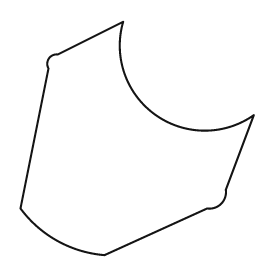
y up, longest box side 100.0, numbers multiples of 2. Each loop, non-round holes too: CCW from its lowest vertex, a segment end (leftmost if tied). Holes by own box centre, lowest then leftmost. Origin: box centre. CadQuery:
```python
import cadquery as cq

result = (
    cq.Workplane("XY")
    .moveTo(-14.0, -50.0)
    .lineTo(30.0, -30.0)
    .threePointArc((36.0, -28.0), (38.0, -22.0))
    .lineTo(50.0, 10.0)
    .threePointArc((8.0, 10.0), (-6.0, 50.0))
    .lineTo(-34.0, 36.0)
    .threePointArc((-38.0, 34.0), (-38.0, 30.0))
    .lineTo(-50.0, -30.0)
    .threePointArc((-34.0, -44.0), (-14.0, -50.0))
    .close()
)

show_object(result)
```